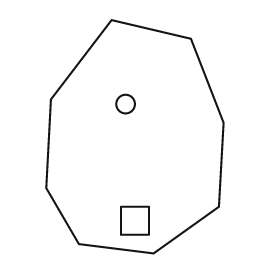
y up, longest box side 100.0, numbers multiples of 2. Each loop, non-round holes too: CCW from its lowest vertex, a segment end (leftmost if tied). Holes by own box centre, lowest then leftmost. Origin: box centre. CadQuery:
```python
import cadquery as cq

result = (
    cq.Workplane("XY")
    .moveTo(8.0, -50.0)
    .lineTo(36.0, -30.0)
    .lineTo(38.0, 6.0)
    .lineTo(24.0, 42.0)
    .lineTo(-10.0, 50.0)
    .lineTo(-36.0, 16.0)
    .lineTo(-38.0, -22.0)
    .lineTo(-24.0, -46.0)
    .close()
    .moveTo(-6.0, -42.0)
    .lineTo(6.0, -42.0)
    .lineTo(6.0, -30.0)
    .lineTo(-6.0, -30.0)
    .close()
    .moveTo(-4.0, 14.0)
    .circle(4.0)
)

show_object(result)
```